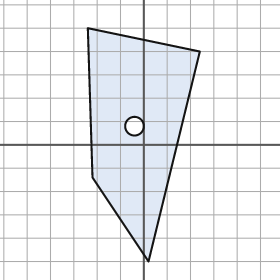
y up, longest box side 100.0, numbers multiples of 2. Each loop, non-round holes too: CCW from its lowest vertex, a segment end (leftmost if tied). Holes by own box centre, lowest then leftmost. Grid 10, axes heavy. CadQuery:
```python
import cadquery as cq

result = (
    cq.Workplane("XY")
    .moveTo(2.0, -50.0)
    .lineTo(24.0, 40.0)
    .lineTo(-24.0, 50.0)
    .lineTo(-22.0, -14.0)
    .close()
    .moveTo(-4.0, 8.0)
    .circle(4.0)
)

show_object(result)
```